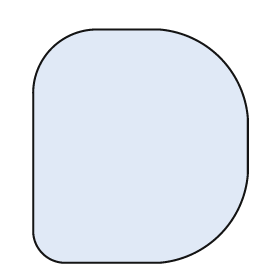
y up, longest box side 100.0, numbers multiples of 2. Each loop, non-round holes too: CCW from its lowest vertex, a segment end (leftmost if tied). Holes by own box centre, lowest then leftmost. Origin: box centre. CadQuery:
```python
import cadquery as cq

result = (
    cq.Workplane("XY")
    .moveTo(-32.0, -50.0)
    .lineTo(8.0, -50.0)
    .threePointArc((34.0, -38.0), (46.0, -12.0))
    .lineTo(46.0, 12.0)
    .threePointArc((34.0, 38.0), (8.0, 50.0))
    .lineTo(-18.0, 50.0)
    .threePointArc((-38.0, 42.0), (-46.0, 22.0))
    .lineTo(-46.0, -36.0)
    .threePointArc((-42.0, -46.0), (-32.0, -50.0))
    .close()
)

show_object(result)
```